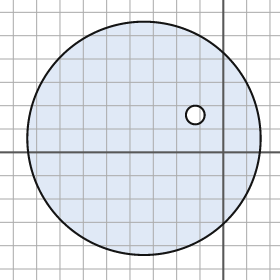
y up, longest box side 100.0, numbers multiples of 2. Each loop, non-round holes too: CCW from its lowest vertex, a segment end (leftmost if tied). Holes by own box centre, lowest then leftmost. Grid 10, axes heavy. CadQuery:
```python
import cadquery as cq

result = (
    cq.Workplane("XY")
    .moveTo(-34.0, 6.0)
    .circle(50.0)
    .moveTo(-12.0, 16.0)
    .circle(4.0)
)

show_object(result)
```